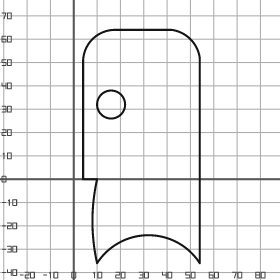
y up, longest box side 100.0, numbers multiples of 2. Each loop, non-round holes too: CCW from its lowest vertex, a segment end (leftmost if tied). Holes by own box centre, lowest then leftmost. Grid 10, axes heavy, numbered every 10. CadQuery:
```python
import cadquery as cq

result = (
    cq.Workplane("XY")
    .moveTo(10.0, -36.0)
    .threePointArc((32.0, -24.0), (54.0, -36.0))
    .lineTo(54.0, 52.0)
    .threePointArc((50.0, 60.0), (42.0, 64.0))
    .lineTo(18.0, 64.0)
    .threePointArc((8.0, 60.0), (4.0, 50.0))
    .lineTo(4.0, 0.0)
    .lineTo(10.0, 0.0)
    .threePointArc((8.0, -18.0), (10.0, -36.0))
    .close()
    .moveTo(16.0, 32.0)
    .circle(6.0)
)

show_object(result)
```